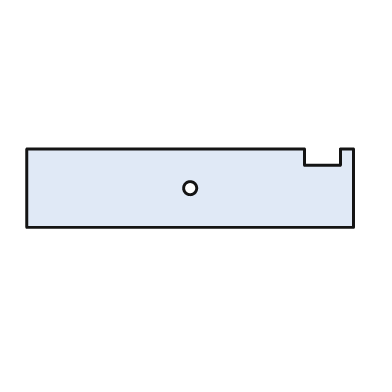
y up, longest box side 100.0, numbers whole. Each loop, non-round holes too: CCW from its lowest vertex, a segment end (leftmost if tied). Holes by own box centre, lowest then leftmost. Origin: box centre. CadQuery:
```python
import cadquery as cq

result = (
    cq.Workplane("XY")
    .moveTo(-50.0, -12.0)
    .lineTo(50.0, -12.0)
    .lineTo(50.0, 12.0)
    .lineTo(46.0, 12.0)
    .lineTo(46.0, 7.0)
    .lineTo(35.0, 7.0)
    .lineTo(35.0, 12.0)
    .lineTo(-50.0, 12.0)
    .close()
    .moveTo(0.0, 0.0)
    .circle(2.0)
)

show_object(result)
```